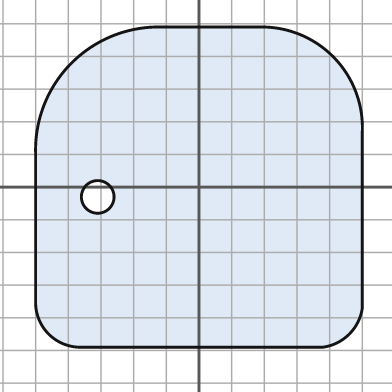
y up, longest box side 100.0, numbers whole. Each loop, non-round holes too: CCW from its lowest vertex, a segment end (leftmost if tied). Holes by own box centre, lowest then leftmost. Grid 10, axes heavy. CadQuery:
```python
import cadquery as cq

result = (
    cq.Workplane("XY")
    .moveTo(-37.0, -49.0)
    .lineTo(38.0, -49.0)
    .threePointArc((46.0, -45.0), (50.0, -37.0))
    .lineTo(50.0, 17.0)
    .threePointArc((41.0, 40.0), (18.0, 49.0))
    .lineTo(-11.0, 49.0)
    .threePointArc((-39.0, 38.0), (-50.0, 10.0))
    .lineTo(-50.0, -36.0)
    .threePointArc((-46.0, -45.0), (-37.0, -49.0))
    .close()
    .moveTo(-31.0, -3.0)
    .circle(5.0)
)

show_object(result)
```